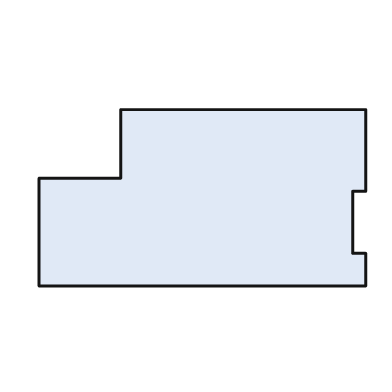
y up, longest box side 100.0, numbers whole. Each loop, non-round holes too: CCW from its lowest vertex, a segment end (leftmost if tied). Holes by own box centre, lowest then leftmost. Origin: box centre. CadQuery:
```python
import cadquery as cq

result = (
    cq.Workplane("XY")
    .moveTo(-50.0, -27.0)
    .lineTo(50.0, -27.0)
    .lineTo(50.0, -17.0)
    .lineTo(46.0, -17.0)
    .lineTo(46.0, 2.0)
    .lineTo(50.0, 2.0)
    .lineTo(50.0, 27.0)
    .lineTo(-25.0, 27.0)
    .lineTo(-25.0, 6.0)
    .lineTo(-50.0, 6.0)
    .close()
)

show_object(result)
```